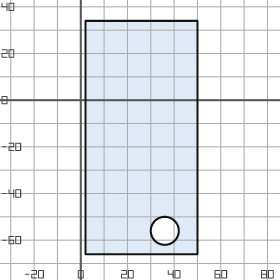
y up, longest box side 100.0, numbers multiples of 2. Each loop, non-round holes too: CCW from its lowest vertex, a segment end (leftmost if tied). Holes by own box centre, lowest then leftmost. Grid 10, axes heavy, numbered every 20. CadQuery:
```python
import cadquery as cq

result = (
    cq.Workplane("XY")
    .moveTo(2.0, -66.0)
    .lineTo(50.0, -66.0)
    .lineTo(50.0, 34.0)
    .lineTo(2.0, 34.0)
    .close()
    .moveTo(36.0, -56.0)
    .circle(6.0)
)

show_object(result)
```